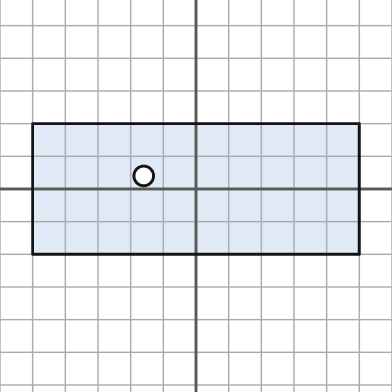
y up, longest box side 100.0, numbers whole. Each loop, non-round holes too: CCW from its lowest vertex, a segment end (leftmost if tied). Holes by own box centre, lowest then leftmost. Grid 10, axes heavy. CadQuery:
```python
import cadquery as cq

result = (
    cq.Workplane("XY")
    .moveTo(-50.0, -20.0)
    .lineTo(50.0, -20.0)
    .lineTo(50.0, 20.0)
    .lineTo(-50.0, 20.0)
    .close()
    .moveTo(-16.0, 4.0)
    .circle(3.0)
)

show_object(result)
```